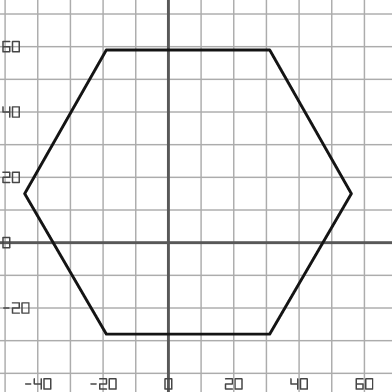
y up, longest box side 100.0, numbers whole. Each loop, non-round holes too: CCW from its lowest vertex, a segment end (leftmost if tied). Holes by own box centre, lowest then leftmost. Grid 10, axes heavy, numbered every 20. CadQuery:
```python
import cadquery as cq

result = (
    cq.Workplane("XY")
    .moveTo(-19.0, -28.0)
    .lineTo(31.0, -28.0)
    .lineTo(56.0, 15.0)
    .lineTo(31.0, 59.0)
    .lineTo(-19.0, 59.0)
    .lineTo(-44.0, 15.0)
    .close()
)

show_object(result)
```